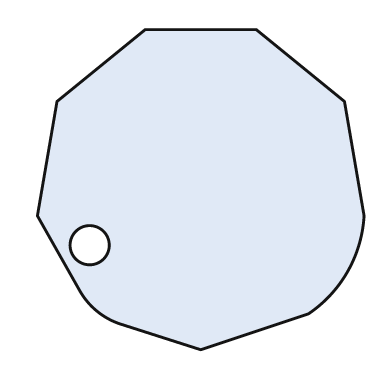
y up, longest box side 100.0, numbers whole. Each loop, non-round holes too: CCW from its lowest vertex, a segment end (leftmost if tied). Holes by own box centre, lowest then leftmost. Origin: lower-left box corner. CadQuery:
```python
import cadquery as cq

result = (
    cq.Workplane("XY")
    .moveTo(50.0, 0.0)
    .lineTo(83.0, 11.0)
    .threePointArc((95.0, 24.0), (100.0, 41.0))
    .lineTo(94.0, 76.0)
    .lineTo(67.0, 98.0)
    .lineTo(33.0, 98.0)
    .lineTo(6.0, 76.0)
    .lineTo(0.0, 41.0)
    .lineTo(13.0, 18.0)
    .threePointArc((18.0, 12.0), (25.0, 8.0))
    .close()
    .moveTo(16.0, 32.0)
    .circle(6.0)
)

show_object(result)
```